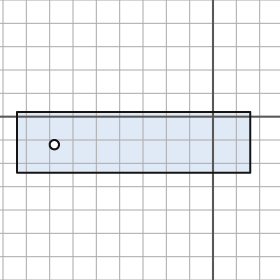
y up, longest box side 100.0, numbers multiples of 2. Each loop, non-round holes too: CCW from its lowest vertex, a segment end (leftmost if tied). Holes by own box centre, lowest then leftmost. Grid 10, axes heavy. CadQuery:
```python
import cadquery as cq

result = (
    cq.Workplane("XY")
    .moveTo(-84.0, -24.0)
    .lineTo(16.0, -24.0)
    .lineTo(16.0, 2.0)
    .lineTo(-84.0, 2.0)
    .close()
    .moveTo(-68.0, -12.0)
    .circle(2.0)
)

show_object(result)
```